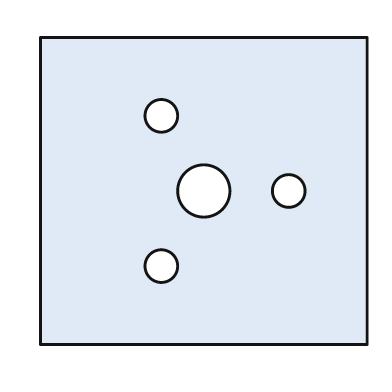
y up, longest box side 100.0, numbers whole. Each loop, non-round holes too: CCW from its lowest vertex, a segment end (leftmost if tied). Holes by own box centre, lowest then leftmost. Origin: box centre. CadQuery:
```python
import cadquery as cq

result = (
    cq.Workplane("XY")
    .moveTo(-50.0, -47.0)
    .lineTo(50.0, -47.0)
    .lineTo(50.0, 47.0)
    .lineTo(-50.0, 47.0)
    .close()
    .moveTo(-13.0, -23.0)
    .circle(5.0)
    .moveTo(0.0, 0.0)
    .circle(8.0)
    .moveTo(26.0, 0.0)
    .circle(5.0)
    .moveTo(-13.0, 23.0)
    .circle(5.0)
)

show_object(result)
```